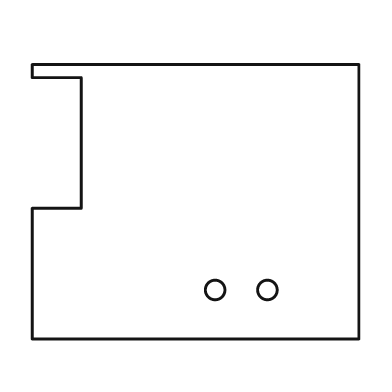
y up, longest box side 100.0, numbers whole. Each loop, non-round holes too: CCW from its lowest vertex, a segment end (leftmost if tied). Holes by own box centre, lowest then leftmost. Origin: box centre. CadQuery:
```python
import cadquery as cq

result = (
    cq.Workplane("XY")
    .moveTo(-50.0, -42.0)
    .lineTo(50.0, -42.0)
    .lineTo(50.0, 42.0)
    .lineTo(-50.0, 42.0)
    .lineTo(-50.0, 38.0)
    .lineTo(-35.0, 38.0)
    .lineTo(-35.0, -2.0)
    .lineTo(-50.0, -2.0)
    .close()
    .moveTo(6.0, -27.0)
    .circle(3.0)
    .moveTo(22.0, -27.0)
    .circle(3.0)
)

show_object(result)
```